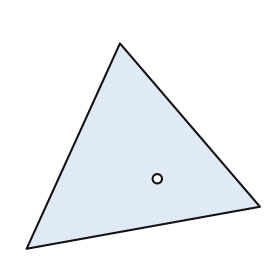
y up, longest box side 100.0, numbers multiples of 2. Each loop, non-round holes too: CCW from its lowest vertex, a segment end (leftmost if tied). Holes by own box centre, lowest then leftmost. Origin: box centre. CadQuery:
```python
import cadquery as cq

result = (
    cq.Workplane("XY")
    .moveTo(-50.0, -44.0)
    .lineTo(50.0, -26.0)
    .lineTo(-10.0, 44.0)
    .close()
    .moveTo(6.0, -14.0)
    .circle(2.0)
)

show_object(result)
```